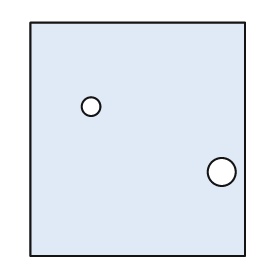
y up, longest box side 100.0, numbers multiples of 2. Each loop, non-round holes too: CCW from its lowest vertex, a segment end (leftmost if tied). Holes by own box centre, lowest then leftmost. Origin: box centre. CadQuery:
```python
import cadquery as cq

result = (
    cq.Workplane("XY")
    .moveTo(-46.0, -50.0)
    .lineTo(46.0, -50.0)
    .lineTo(46.0, 50.0)
    .lineTo(-46.0, 50.0)
    .close()
    .moveTo(36.0, -14.0)
    .circle(6.0)
    .moveTo(-20.0, 14.0)
    .circle(4.0)
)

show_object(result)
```